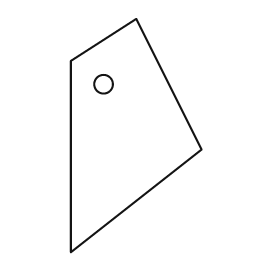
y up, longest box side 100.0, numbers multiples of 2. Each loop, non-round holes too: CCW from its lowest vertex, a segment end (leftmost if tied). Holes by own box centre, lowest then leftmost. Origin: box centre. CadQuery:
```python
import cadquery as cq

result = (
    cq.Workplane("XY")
    .moveTo(-28.0, -50.0)
    .lineTo(28.0, -6.0)
    .lineTo(0.0, 50.0)
    .lineTo(-28.0, 32.0)
    .close()
    .moveTo(-14.0, 22.0)
    .circle(4.0)
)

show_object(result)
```